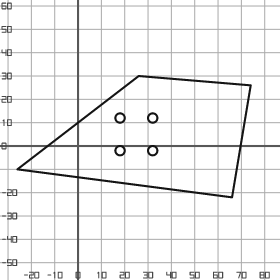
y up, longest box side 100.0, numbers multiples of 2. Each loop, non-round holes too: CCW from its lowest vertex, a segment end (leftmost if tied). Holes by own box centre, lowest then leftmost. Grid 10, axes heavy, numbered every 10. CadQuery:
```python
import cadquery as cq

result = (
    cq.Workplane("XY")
    .moveTo(66.0, -22.0)
    .lineTo(74.0, 26.0)
    .lineTo(26.0, 30.0)
    .lineTo(-26.0, -10.0)
    .close()
    .moveTo(18.0, -2.0)
    .circle(2.0)
    .moveTo(32.0, -2.0)
    .circle(2.0)
    .moveTo(18.0, 12.0)
    .circle(2.0)
    .moveTo(32.0, 12.0)
    .circle(2.0)
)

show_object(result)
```